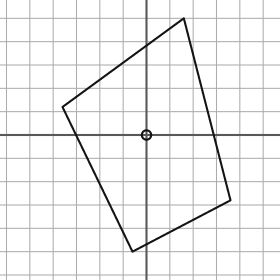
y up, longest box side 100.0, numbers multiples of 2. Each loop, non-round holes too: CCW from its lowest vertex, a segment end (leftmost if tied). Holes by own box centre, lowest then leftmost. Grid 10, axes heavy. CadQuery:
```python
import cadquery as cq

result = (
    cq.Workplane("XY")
    .moveTo(-6.0, -50.0)
    .lineTo(36.0, -28.0)
    .lineTo(16.0, 50.0)
    .lineTo(-36.0, 12.0)
    .close()
    .moveTo(0.0, 0.0)
    .circle(2.0)
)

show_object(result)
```